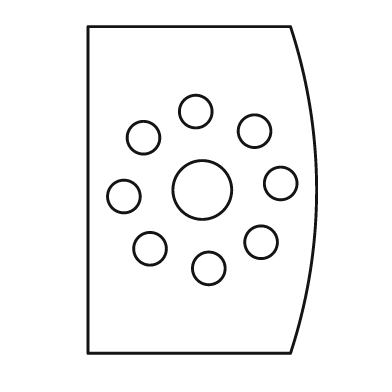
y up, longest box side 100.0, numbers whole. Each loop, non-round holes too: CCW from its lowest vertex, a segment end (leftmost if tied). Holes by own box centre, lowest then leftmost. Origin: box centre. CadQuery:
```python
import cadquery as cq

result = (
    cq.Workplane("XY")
    .moveTo(-35.0, -50.0)
    .lineTo(27.0, -50.0)
    .threePointArc((35.0, 0.0), (27.0, 50.0))
    .lineTo(-35.0, 50.0)
    .close()
    .moveTo(2.0, -24.0)
    .circle(5.0)
    .moveTo(-16.0, -18.0)
    .circle(5.0)
    .moveTo(18.0, -16.0)
    .circle(5.0)
    .moveTo(-24.0, -2.0)
    .circle(5.0)
    .moveTo(0.0, 0.0)
    .circle(9.0)
    .moveTo(24.0, 2.0)
    .circle(5.0)
    .moveTo(-18.0, 16.0)
    .circle(5.0)
    .moveTo(16.0, 18.0)
    .circle(5.0)
    .moveTo(-2.0, 24.0)
    .circle(5.0)
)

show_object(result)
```